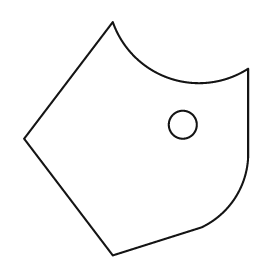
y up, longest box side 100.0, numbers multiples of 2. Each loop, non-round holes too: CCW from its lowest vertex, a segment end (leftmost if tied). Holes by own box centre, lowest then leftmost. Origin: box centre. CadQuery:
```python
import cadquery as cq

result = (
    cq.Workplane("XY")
    .moveTo(-10.0, -50.0)
    .lineTo(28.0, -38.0)
    .threePointArc((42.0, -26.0), (48.0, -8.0))
    .lineTo(48.0, 30.0)
    .threePointArc((14.0, 26.0), (-10.0, 50.0))
    .lineTo(-48.0, 0.0)
    .close()
    .moveTo(20.0, 6.0)
    .circle(6.0)
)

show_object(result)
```